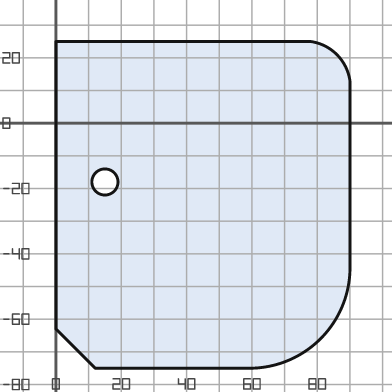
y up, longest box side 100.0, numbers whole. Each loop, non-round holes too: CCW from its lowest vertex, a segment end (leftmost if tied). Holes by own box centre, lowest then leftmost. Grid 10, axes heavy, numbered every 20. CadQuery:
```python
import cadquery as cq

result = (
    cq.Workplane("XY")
    .moveTo(12.0, -75.0)
    .lineTo(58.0, -75.0)
    .threePointArc((81.0, -66.0), (90.0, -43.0))
    .lineTo(90.0, 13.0)
    .threePointArc((86.0, 21.0), (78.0, 25.0))
    .lineTo(0.0, 25.0)
    .lineTo(0.0, -63.0)
    .close()
    .moveTo(15.0, -18.0)
    .circle(4.0)
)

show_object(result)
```